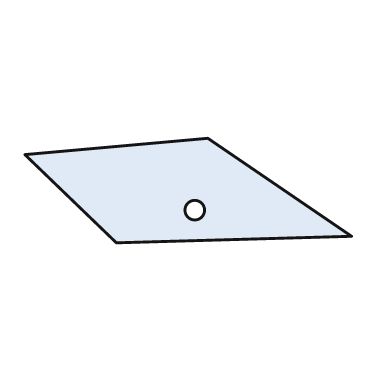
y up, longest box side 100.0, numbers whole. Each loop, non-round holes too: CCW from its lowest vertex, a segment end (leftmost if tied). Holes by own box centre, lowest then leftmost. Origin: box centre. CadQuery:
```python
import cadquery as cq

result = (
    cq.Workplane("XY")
    .moveTo(-22.0, -16.0)
    .lineTo(50.0, -14.0)
    .lineTo(6.0, 16.0)
    .lineTo(-50.0, 11.0)
    .close()
    .moveTo(2.0, -6.0)
    .circle(3.0)
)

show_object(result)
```